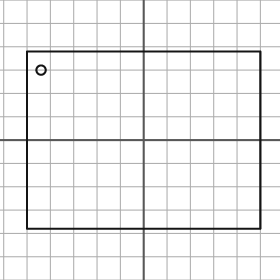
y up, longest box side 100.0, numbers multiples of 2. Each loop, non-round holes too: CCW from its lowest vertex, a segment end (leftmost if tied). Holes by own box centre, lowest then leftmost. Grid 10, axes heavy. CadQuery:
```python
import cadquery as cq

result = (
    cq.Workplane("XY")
    .moveTo(-50.0, -38.0)
    .lineTo(50.0, -38.0)
    .lineTo(50.0, 38.0)
    .lineTo(-50.0, 38.0)
    .close()
    .moveTo(-44.0, 30.0)
    .circle(2.0)
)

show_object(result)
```